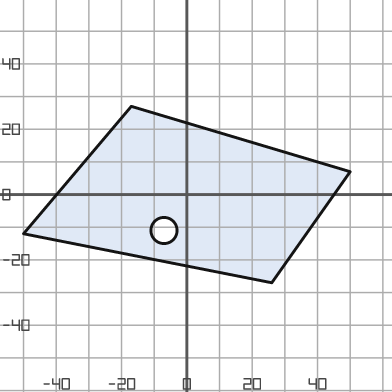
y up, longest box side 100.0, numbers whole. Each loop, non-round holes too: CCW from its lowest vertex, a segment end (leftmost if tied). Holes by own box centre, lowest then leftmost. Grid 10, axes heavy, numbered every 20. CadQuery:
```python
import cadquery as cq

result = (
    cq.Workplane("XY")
    .moveTo(26.0, -27.0)
    .lineTo(50.0, 7.0)
    .lineTo(-17.0, 27.0)
    .lineTo(-50.0, -12.0)
    .close()
    .moveTo(-7.0, -11.0)
    .circle(4.0)
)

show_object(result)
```